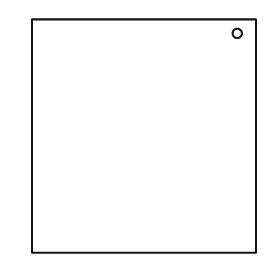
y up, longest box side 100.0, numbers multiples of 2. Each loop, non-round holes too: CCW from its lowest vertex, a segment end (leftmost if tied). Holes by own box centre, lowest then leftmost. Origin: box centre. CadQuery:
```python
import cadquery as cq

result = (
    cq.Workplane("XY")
    .moveTo(-48.0, -50.0)
    .lineTo(48.0, -50.0)
    .lineTo(48.0, 50.0)
    .lineTo(-48.0, 50.0)
    .close()
    .moveTo(40.0, 44.0)
    .circle(2.0)
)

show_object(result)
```